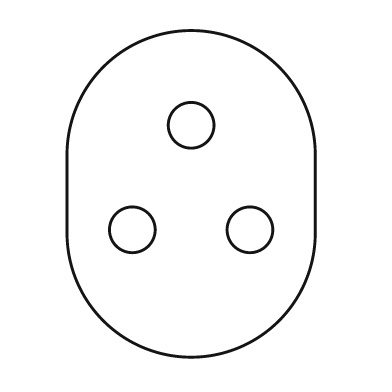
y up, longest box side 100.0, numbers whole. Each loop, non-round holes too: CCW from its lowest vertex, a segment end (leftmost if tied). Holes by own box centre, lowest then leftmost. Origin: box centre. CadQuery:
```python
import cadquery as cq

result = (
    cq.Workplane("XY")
    .moveTo(-38.0, -12.0)
    .threePointArc((0.0, -50.0), (38.0, -12.0))
    .lineTo(38.0, 12.0)
    .threePointArc((0.0, 50.0), (-38.0, 12.0))
    .close()
    .moveTo(-18.0, -11.0)
    .circle(7.0)
    .moveTo(18.0, -11.0)
    .circle(7.0)
    .moveTo(0.0, 21.0)
    .circle(7.0)
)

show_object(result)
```